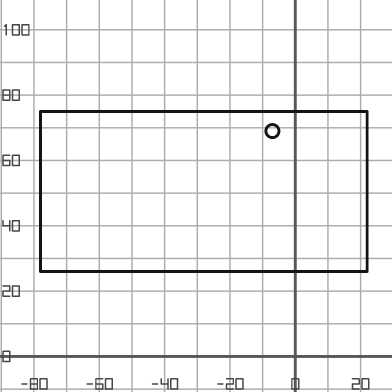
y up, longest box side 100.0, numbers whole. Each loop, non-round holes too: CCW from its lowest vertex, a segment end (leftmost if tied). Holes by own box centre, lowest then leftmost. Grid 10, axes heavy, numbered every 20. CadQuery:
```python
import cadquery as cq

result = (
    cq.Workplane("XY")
    .moveTo(-78.0, 26.0)
    .lineTo(22.0, 26.0)
    .lineTo(22.0, 75.0)
    .lineTo(-78.0, 75.0)
    .close()
    .moveTo(-7.0, 69.0)
    .circle(2.0)
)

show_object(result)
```